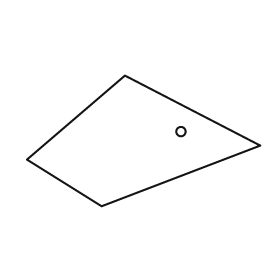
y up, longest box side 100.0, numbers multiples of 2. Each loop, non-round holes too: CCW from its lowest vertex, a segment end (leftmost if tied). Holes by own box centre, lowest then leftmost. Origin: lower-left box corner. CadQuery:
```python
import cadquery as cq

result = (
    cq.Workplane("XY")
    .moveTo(32.0, 0.0)
    .lineTo(100.0, 26.0)
    .lineTo(42.0, 56.0)
    .lineTo(0.0, 20.0)
    .close()
    .moveTo(66.0, 32.0)
    .circle(2.0)
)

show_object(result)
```